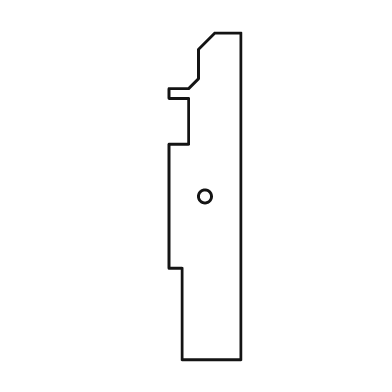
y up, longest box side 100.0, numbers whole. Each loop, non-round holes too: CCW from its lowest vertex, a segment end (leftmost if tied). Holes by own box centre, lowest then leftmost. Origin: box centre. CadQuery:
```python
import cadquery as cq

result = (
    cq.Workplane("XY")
    .moveTo(-7.0, -50.0)
    .lineTo(11.0, -50.0)
    .lineTo(11.0, 50.0)
    .lineTo(3.0, 50.0)
    .lineTo(-2.0, 45.0)
    .lineTo(-2.0, 36.0)
    .lineTo(-5.0, 33.0)
    .lineTo(-11.0, 33.0)
    .lineTo(-11.0, 30.0)
    .lineTo(-5.0, 30.0)
    .lineTo(-5.0, 16.0)
    .lineTo(-11.0, 16.0)
    .lineTo(-11.0, -22.0)
    .lineTo(-7.0, -22.0)
    .close()
    .moveTo(0.0, 0.0)
    .circle(2.0)
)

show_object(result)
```